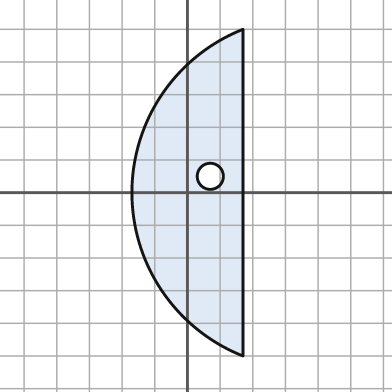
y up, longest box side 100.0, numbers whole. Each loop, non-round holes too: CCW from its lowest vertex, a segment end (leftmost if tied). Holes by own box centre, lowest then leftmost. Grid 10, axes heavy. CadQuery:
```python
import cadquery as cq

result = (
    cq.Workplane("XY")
    .moveTo(17.0, -50.0)
    .lineTo(17.0, 50.0)
    .threePointArc((-17.0, 0.0), (17.0, -50.0))
    .close()
    .moveTo(7.0, 5.0)
    .circle(4.0)
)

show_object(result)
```